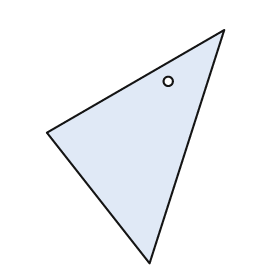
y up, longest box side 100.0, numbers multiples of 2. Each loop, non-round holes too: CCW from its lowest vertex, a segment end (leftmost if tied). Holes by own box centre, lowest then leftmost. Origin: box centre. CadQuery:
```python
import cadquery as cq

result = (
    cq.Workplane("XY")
    .moveTo(6.0, -50.0)
    .lineTo(38.0, 50.0)
    .lineTo(-38.0, 6.0)
    .close()
    .moveTo(14.0, 28.0)
    .circle(2.0)
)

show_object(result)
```